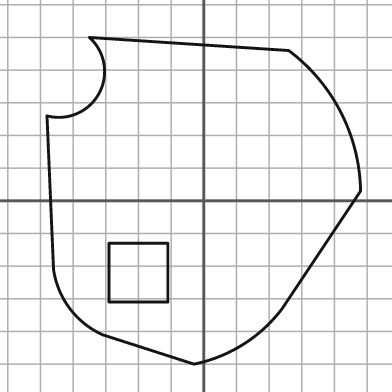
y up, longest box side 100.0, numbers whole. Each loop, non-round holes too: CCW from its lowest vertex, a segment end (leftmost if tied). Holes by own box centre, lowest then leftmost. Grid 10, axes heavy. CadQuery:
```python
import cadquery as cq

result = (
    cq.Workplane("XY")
    .moveTo(-3.0, -50.0)
    .threePointArc((12.0, -44.0), (24.0, -33.0))
    .lineTo(48.0, 3.0)
    .threePointArc((42.0, 27.0), (26.0, 46.0))
    .lineTo(-35.0, 50.0)
    .threePointArc((-32.0, 33.0), (-48.0, 26.0))
    .lineTo(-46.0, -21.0)
    .threePointArc((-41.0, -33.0), (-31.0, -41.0))
    .close()
    .moveTo(-29.0, -31.0)
    .lineTo(-11.0, -31.0)
    .lineTo(-11.0, -13.0)
    .lineTo(-29.0, -13.0)
    .close()
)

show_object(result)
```